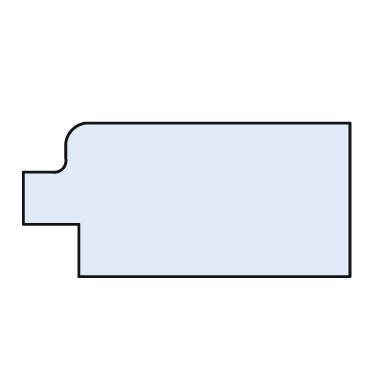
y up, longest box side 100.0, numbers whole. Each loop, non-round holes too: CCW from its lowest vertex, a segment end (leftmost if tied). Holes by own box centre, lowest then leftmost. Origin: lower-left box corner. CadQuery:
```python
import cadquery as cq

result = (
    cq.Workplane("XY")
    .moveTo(17.0, 0.0)
    .lineTo(100.0, 0.0)
    .lineTo(100.0, 47.0)
    .lineTo(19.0, 47.0)
    .threePointArc((15.0, 45.0), (13.0, 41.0))
    .lineTo(13.0, 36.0)
    .threePointArc((12.0, 33.0), (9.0, 32.0))
    .lineTo(0.0, 32.0)
    .lineTo(0.0, 16.0)
    .lineTo(17.0, 16.0)
    .close()
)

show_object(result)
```